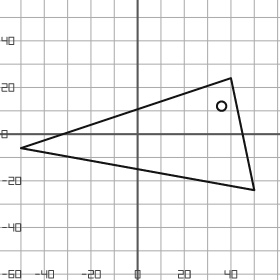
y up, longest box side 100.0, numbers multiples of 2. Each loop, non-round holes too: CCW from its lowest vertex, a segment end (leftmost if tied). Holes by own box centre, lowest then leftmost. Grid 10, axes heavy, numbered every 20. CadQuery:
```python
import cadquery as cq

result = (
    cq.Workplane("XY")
    .moveTo(50.0, -24.0)
    .lineTo(40.0, 24.0)
    .lineTo(-50.0, -6.0)
    .close()
    .moveTo(36.0, 12.0)
    .circle(2.0)
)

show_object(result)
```